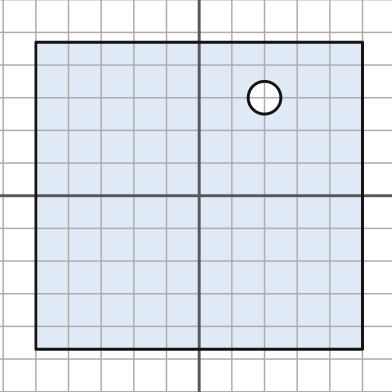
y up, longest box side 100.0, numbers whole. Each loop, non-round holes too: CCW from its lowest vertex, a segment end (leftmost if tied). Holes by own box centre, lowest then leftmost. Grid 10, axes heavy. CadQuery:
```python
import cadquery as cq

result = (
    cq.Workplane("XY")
    .moveTo(-50.0, -47.0)
    .lineTo(50.0, -47.0)
    .lineTo(50.0, 47.0)
    .lineTo(-50.0, 47.0)
    .close()
    .moveTo(20.0, 30.0)
    .circle(5.0)
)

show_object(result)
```